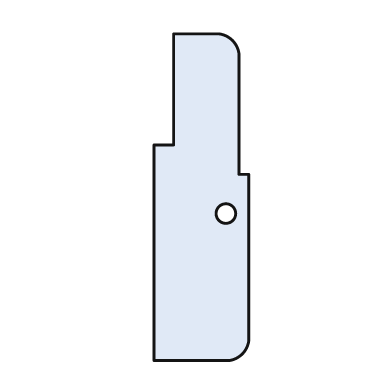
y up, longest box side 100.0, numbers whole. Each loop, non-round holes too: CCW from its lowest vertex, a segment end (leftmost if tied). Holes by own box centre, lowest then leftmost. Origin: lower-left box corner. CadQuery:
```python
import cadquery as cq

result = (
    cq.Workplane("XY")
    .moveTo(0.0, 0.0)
    .lineTo(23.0, 0.0)
    .threePointArc((27.0, 2.0), (29.0, 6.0))
    .lineTo(29.0, 57.0)
    .lineTo(26.0, 57.0)
    .lineTo(26.0, 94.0)
    .threePointArc((24.0, 98.0), (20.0, 100.0))
    .lineTo(6.0, 100.0)
    .lineTo(6.0, 66.0)
    .lineTo(0.0, 66.0)
    .close()
    .moveTo(22.0, 45.0)
    .circle(3.0)
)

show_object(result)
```